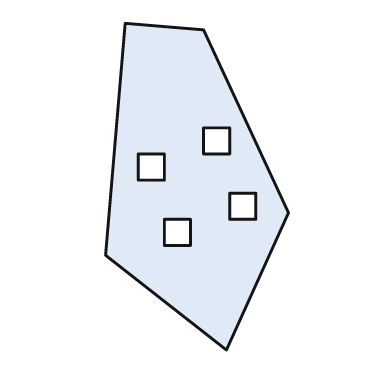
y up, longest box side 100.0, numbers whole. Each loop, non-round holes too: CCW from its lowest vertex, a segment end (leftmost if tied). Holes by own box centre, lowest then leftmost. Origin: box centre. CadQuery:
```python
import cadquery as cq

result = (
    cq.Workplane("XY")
    .moveTo(9.0, -50.0)
    .lineTo(28.0, -8.0)
    .lineTo(2.0, 48.0)
    .lineTo(-22.0, 50.0)
    .lineTo(-28.0, -21.0)
    .close()
    .moveTo(-10.0, -18.0)
    .lineTo(-2.0, -18.0)
    .lineTo(-2.0, -10.0)
    .lineTo(-10.0, -10.0)
    .close()
    .moveTo(10.0, -10.0)
    .lineTo(18.0, -10.0)
    .lineTo(18.0, -2.0)
    .lineTo(10.0, -2.0)
    .close()
    .moveTo(-18.0, 2.0)
    .lineTo(-10.0, 2.0)
    .lineTo(-10.0, 10.0)
    .lineTo(-18.0, 10.0)
    .close()
    .moveTo(2.0, 10.0)
    .lineTo(10.0, 10.0)
    .lineTo(10.0, 18.0)
    .lineTo(2.0, 18.0)
    .close()
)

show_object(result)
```